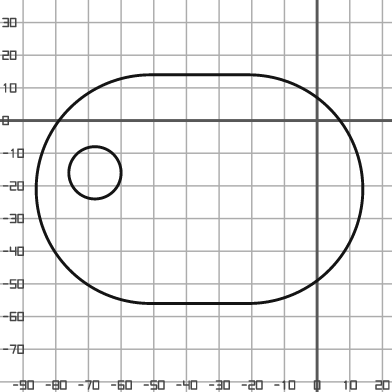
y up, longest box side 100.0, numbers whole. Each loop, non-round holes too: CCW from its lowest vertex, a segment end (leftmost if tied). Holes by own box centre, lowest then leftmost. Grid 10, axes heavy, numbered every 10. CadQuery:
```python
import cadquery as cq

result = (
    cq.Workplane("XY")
    .moveTo(-51.0, -56.0)
    .lineTo(-21.0, -56.0)
    .threePointArc((14.0, -21.0), (-21.0, 14.0))
    .lineTo(-51.0, 14.0)
    .threePointArc((-86.0, -21.0), (-51.0, -56.0))
    .close()
    .moveTo(-68.0, -16.0)
    .circle(8.0)
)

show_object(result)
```